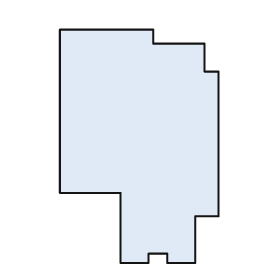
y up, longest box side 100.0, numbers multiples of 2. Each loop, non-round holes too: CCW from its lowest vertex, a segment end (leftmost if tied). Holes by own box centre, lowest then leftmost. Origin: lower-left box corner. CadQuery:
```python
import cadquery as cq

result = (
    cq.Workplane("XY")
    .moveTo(26.0, 0.0)
    .lineTo(38.0, 0.0)
    .lineTo(38.0, 4.0)
    .lineTo(46.0, 4.0)
    .lineTo(46.0, 0.0)
    .lineTo(58.0, 0.0)
    .lineTo(58.0, 20.0)
    .lineTo(68.0, 20.0)
    .lineTo(68.0, 82.0)
    .lineTo(62.0, 82.0)
    .lineTo(62.0, 94.0)
    .lineTo(40.0, 94.0)
    .lineTo(40.0, 100.0)
    .lineTo(0.0, 100.0)
    .lineTo(0.0, 30.0)
    .lineTo(26.0, 30.0)
    .close()
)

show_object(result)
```